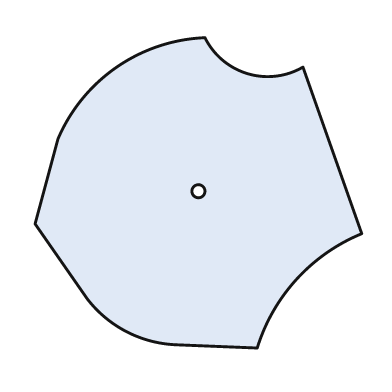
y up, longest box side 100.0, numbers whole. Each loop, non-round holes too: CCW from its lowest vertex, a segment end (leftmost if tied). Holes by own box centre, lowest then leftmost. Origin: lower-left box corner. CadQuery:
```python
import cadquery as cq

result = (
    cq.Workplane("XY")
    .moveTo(68.0, 0.0)
    .threePointArc((80.0, 21.0), (100.0, 35.0))
    .lineTo(82.0, 86.0)
    .threePointArc((65.0, 84.0), (52.0, 95.0))
    .threePointArc((25.0, 86.0), (7.0, 64.0))
    .lineTo(0.0, 38.0)
    .lineTo(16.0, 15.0)
    .threePointArc((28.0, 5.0), (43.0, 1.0))
    .close()
    .moveTo(50.0, 48.0)
    .circle(2.0)
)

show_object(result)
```